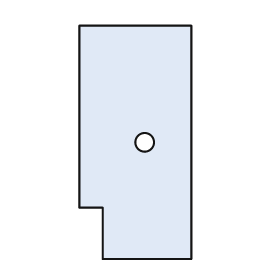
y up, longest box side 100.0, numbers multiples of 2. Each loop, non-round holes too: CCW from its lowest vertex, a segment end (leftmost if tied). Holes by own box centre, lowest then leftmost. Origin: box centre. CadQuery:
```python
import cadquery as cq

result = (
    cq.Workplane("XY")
    .moveTo(-14.0, -50.0)
    .lineTo(24.0, -50.0)
    .lineTo(24.0, 50.0)
    .lineTo(-24.0, 50.0)
    .lineTo(-24.0, -28.0)
    .lineTo(-14.0, -28.0)
    .close()
    .moveTo(4.0, 0.0)
    .circle(4.0)
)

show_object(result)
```